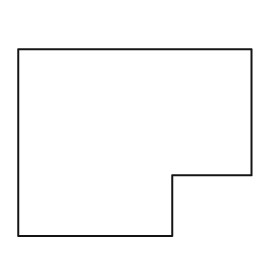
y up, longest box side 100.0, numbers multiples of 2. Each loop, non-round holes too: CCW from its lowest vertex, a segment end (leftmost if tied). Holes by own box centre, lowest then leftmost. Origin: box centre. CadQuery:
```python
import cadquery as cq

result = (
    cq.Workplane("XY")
    .moveTo(-50.0, -40.0)
    .lineTo(16.0, -40.0)
    .lineTo(16.0, -14.0)
    .lineTo(50.0, -14.0)
    .lineTo(50.0, 40.0)
    .lineTo(-50.0, 40.0)
    .close()
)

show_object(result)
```